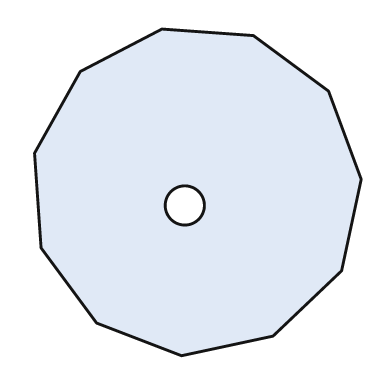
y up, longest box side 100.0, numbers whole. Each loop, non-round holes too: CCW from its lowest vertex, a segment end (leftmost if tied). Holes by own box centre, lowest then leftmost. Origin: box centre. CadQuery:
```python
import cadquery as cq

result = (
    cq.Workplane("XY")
    .moveTo(-5.0, -50.0)
    .lineTo(23.0, -44.0)
    .lineTo(44.0, -24.0)
    .lineTo(50.0, 4.0)
    .lineTo(40.0, 31.0)
    .lineTo(17.0, 48.0)
    .lineTo(-11.0, 50.0)
    .lineTo(-36.0, 37.0)
    .lineTo(-50.0, 12.0)
    .lineTo(-48.0, -17.0)
    .lineTo(-31.0, -40.0)
    .close()
    .moveTo(-4.0, -4.0)
    .circle(6.0)
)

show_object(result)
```